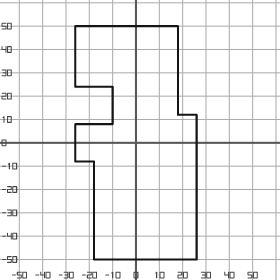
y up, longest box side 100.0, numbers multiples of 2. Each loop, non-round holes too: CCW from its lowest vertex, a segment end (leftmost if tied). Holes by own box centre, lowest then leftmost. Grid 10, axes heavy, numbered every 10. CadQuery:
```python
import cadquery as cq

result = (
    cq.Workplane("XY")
    .moveTo(-18.0, -50.0)
    .lineTo(26.0, -50.0)
    .lineTo(26.0, 12.0)
    .lineTo(18.0, 12.0)
    .lineTo(18.0, 50.0)
    .lineTo(-26.0, 50.0)
    .lineTo(-26.0, 24.0)
    .lineTo(-10.0, 24.0)
    .lineTo(-10.0, 8.0)
    .lineTo(-26.0, 8.0)
    .lineTo(-26.0, -8.0)
    .lineTo(-18.0, -8.0)
    .close()
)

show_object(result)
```